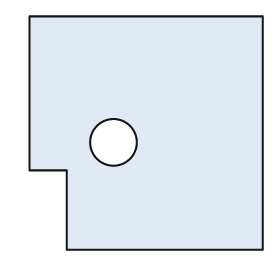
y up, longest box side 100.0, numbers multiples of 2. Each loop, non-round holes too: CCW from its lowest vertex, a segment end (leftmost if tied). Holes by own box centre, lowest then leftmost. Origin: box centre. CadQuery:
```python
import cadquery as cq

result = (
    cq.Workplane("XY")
    .moveTo(-34.0, -50.0)
    .lineTo(50.0, -50.0)
    .lineTo(50.0, 50.0)
    .lineTo(-50.0, 50.0)
    .lineTo(-50.0, -16.0)
    .lineTo(-34.0, -16.0)
    .close()
    .moveTo(-14.0, -4.0)
    .circle(10.0)
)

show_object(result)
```